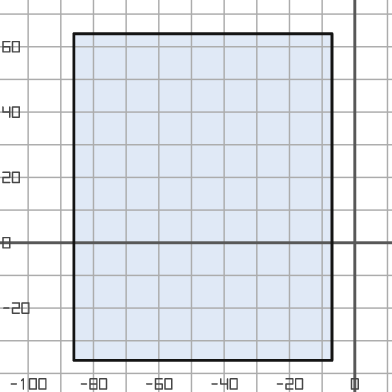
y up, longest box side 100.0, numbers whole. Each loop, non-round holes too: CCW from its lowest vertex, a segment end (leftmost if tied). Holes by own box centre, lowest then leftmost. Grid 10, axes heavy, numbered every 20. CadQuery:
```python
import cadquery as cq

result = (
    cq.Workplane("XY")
    .moveTo(-86.0, -36.0)
    .lineTo(-7.0, -36.0)
    .lineTo(-7.0, 64.0)
    .lineTo(-86.0, 64.0)
    .close()
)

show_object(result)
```